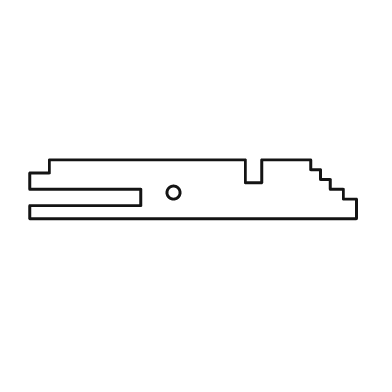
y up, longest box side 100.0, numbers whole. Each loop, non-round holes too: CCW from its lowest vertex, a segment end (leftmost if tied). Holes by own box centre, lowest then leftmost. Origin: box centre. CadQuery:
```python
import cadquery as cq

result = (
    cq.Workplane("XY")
    .moveTo(-50.0, -9.0)
    .lineTo(50.0, -9.0)
    .lineTo(50.0, -3.0)
    .lineTo(46.0, -3.0)
    .lineTo(46.0, 0.0)
    .lineTo(42.0, 0.0)
    .lineTo(42.0, 3.0)
    .lineTo(39.0, 3.0)
    .lineTo(39.0, 6.0)
    .lineTo(36.0, 6.0)
    .lineTo(36.0, 9.0)
    .lineTo(21.0, 9.0)
    .lineTo(21.0, 2.0)
    .lineTo(16.0, 2.0)
    .lineTo(16.0, 9.0)
    .lineTo(-44.0, 9.0)
    .lineTo(-44.0, 5.0)
    .lineTo(-50.0, 5.0)
    .lineTo(-50.0, 0.0)
    .lineTo(-16.0, 0.0)
    .lineTo(-16.0, -5.0)
    .lineTo(-50.0, -5.0)
    .close()
    .moveTo(-6.0, -1.0)
    .circle(2.0)
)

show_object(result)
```